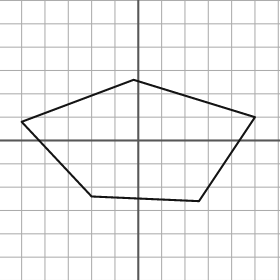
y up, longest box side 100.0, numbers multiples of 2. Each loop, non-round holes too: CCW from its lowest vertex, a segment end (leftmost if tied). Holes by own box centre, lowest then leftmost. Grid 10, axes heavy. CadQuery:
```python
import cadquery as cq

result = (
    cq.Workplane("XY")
    .moveTo(26.0, -26.0)
    .lineTo(50.0, 10.0)
    .lineTo(-2.0, 26.0)
    .lineTo(-50.0, 8.0)
    .lineTo(-20.0, -24.0)
    .close()
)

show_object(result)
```